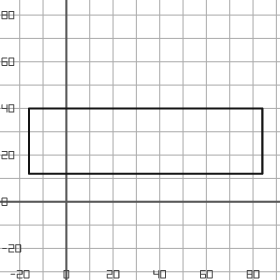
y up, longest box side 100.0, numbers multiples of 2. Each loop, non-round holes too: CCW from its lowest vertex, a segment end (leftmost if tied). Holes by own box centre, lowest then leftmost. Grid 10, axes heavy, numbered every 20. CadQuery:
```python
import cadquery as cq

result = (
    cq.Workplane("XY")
    .moveTo(-16.0, 12.0)
    .lineTo(84.0, 12.0)
    .lineTo(84.0, 40.0)
    .lineTo(-16.0, 40.0)
    .close()
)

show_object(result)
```